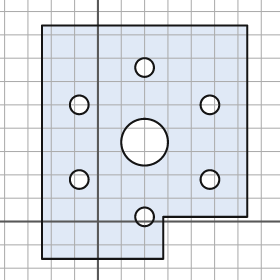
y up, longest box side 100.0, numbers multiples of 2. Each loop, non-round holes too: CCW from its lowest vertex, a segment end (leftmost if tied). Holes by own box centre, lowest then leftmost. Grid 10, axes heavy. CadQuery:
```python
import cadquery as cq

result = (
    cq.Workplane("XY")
    .moveTo(-24.0, -16.0)
    .lineTo(28.0, -16.0)
    .lineTo(28.0, 2.0)
    .lineTo(64.0, 2.0)
    .lineTo(64.0, 84.0)
    .lineTo(-24.0, 84.0)
    .close()
    .moveTo(20.0, 2.0)
    .circle(4.0)
    .moveTo(-8.0, 18.0)
    .circle(4.0)
    .moveTo(48.0, 18.0)
    .circle(4.0)
    .moveTo(20.0, 34.0)
    .circle(10.0)
    .moveTo(-8.0, 50.0)
    .circle(4.0)
    .moveTo(48.0, 50.0)
    .circle(4.0)
    .moveTo(20.0, 66.0)
    .circle(4.0)
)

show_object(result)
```